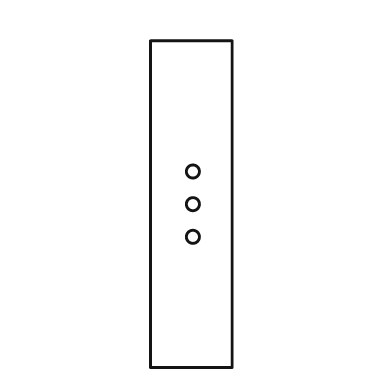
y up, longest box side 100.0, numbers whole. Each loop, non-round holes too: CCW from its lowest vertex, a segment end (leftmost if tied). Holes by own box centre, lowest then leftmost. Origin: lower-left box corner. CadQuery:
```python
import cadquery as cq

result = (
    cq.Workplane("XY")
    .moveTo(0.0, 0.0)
    .lineTo(25.0, 0.0)
    .lineTo(25.0, 100.0)
    .lineTo(0.0, 100.0)
    .close()
    .moveTo(13.0, 40.0)
    .circle(2.0)
    .moveTo(13.0, 50.0)
    .circle(2.0)
    .moveTo(13.0, 60.0)
    .circle(2.0)
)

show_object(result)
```